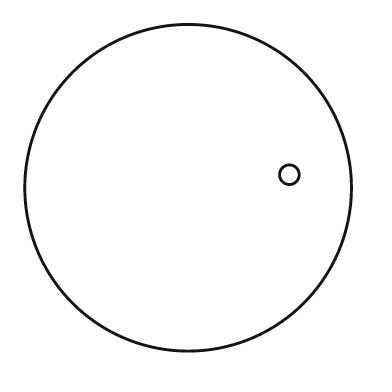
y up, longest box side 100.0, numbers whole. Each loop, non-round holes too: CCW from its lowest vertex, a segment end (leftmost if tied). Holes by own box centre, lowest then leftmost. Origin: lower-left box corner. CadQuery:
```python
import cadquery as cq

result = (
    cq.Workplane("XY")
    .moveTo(50.0, 50.0)
    .circle(50.0)
    .moveTo(81.0, 54.0)
    .circle(3.0)
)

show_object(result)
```